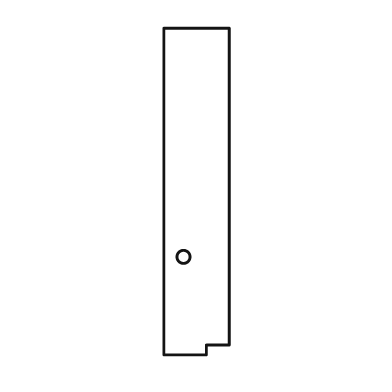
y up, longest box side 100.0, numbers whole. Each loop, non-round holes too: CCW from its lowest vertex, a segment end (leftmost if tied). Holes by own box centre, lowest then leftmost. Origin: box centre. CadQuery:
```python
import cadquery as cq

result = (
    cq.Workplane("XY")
    .moveTo(-10.0, -50.0)
    .lineTo(3.0, -50.0)
    .lineTo(3.0, -47.0)
    .lineTo(10.0, -47.0)
    .lineTo(10.0, 50.0)
    .lineTo(-10.0, 50.0)
    .close()
    .moveTo(-4.0, -20.0)
    .circle(2.0)
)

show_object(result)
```